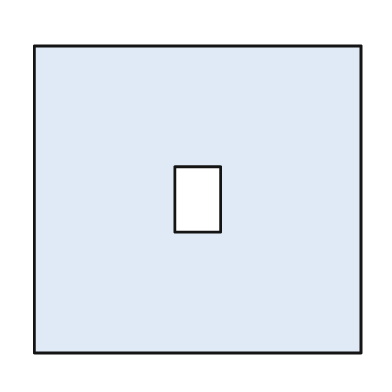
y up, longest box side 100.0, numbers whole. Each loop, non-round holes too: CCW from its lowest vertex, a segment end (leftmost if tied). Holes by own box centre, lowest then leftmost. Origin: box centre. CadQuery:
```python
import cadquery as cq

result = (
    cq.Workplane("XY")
    .moveTo(-50.0, -47.0)
    .lineTo(50.0, -47.0)
    .lineTo(50.0, 47.0)
    .lineTo(-50.0, 47.0)
    .close()
    .moveTo(-7.0, -10.0)
    .lineTo(7.0, -10.0)
    .lineTo(7.0, 10.0)
    .lineTo(-7.0, 10.0)
    .close()
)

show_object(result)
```